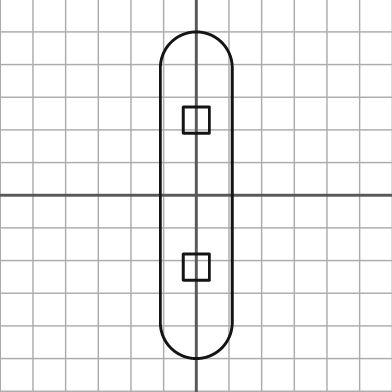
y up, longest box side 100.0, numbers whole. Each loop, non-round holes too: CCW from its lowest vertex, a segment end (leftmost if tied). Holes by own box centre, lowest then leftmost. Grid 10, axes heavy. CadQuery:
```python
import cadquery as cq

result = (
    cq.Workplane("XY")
    .moveTo(-11.0, -39.0)
    .threePointArc((0.0, -50.0), (11.0, -39.0))
    .lineTo(11.0, 39.0)
    .threePointArc((0.0, 50.0), (-11.0, 39.0))
    .close()
    .moveTo(-4.0, -26.0)
    .lineTo(4.0, -26.0)
    .lineTo(4.0, -18.0)
    .lineTo(-4.0, -18.0)
    .close()
    .moveTo(-4.0, 19.0)
    .lineTo(4.0, 19.0)
    .lineTo(4.0, 27.0)
    .lineTo(-4.0, 27.0)
    .close()
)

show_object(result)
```